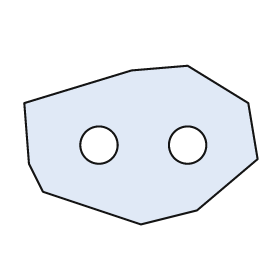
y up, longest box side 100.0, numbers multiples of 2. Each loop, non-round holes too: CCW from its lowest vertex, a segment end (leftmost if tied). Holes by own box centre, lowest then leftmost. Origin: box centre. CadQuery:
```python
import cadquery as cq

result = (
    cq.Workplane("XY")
    .moveTo(0.0, -34.0)
    .lineTo(24.0, -28.0)
    .lineTo(50.0, -6.0)
    .lineTo(46.0, 18.0)
    .lineTo(20.0, 34.0)
    .lineTo(-4.0, 32.0)
    .lineTo(-50.0, 18.0)
    .lineTo(-48.0, -8.0)
    .lineTo(-42.0, -20.0)
    .close()
    .moveTo(-18.0, 0.0)
    .circle(8.0)
    .moveTo(20.0, 0.0)
    .circle(8.0)
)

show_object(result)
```